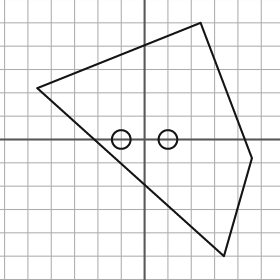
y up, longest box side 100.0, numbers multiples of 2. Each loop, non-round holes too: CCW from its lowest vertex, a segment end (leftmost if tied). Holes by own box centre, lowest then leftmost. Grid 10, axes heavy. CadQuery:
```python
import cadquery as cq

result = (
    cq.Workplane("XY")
    .moveTo(34.0, -50.0)
    .lineTo(46.0, -8.0)
    .lineTo(24.0, 50.0)
    .lineTo(-46.0, 22.0)
    .close()
    .moveTo(-10.0, 0.0)
    .circle(4.0)
    .moveTo(10.0, 0.0)
    .circle(4.0)
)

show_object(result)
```